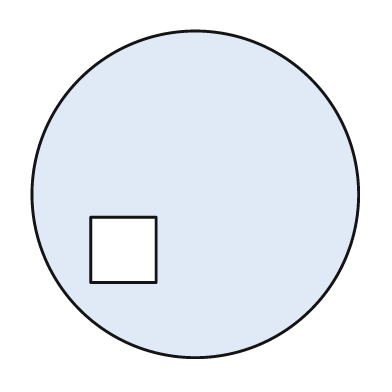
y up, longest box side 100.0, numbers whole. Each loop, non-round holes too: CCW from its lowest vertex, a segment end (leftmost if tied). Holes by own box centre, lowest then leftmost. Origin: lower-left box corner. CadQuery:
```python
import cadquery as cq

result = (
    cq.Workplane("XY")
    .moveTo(50.0, 50.0)
    .circle(50.0)
    .moveTo(18.0, 23.0)
    .lineTo(38.0, 23.0)
    .lineTo(38.0, 43.0)
    .lineTo(18.0, 43.0)
    .close()
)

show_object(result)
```